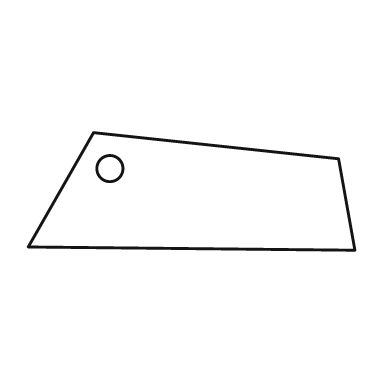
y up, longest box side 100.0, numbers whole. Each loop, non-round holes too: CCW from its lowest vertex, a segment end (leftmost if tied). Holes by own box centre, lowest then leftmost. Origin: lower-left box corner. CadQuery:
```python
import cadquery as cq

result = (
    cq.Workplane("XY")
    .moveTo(100.0, 0.0)
    .lineTo(95.0, 28.0)
    .lineTo(20.0, 36.0)
    .lineTo(0.0, 1.0)
    .close()
    .moveTo(25.0, 25.0)
    .circle(4.0)
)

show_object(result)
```